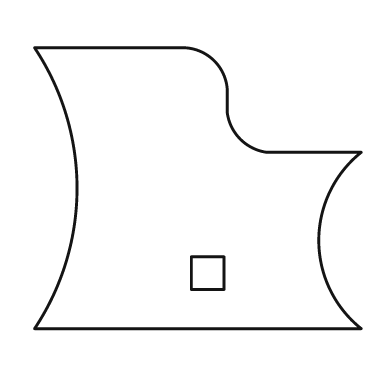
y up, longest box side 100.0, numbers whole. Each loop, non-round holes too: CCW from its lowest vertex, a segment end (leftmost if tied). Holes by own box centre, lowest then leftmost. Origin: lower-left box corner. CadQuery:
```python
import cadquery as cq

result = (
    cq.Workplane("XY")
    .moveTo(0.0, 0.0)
    .lineTo(100.0, 0.0)
    .threePointArc((87.0, 27.0), (100.0, 54.0))
    .lineTo(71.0, 54.0)
    .threePointArc((63.0, 58.0), (59.0, 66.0))
    .lineTo(59.0, 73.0)
    .threePointArc((55.0, 82.0), (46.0, 86.0))
    .lineTo(0.0, 86.0)
    .threePointArc((13.0, 43.0), (0.0, 0.0))
    .close()
    .moveTo(48.0, 12.0)
    .lineTo(58.0, 12.0)
    .lineTo(58.0, 22.0)
    .lineTo(48.0, 22.0)
    .close()
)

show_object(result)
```